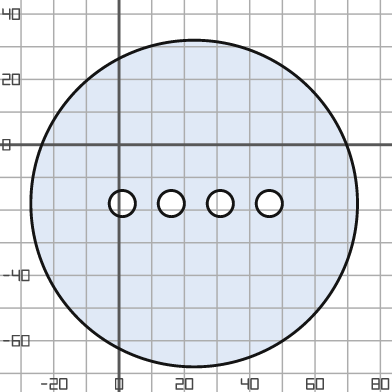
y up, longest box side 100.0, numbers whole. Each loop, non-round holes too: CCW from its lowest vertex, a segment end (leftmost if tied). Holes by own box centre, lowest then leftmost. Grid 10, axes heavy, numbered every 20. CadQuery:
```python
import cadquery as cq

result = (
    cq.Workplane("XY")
    .moveTo(23.0, -18.0)
    .circle(50.0)
    .moveTo(1.0, -18.0)
    .circle(4.0)
    .moveTo(16.0, -18.0)
    .circle(4.0)
    .moveTo(31.0, -18.0)
    .circle(4.0)
    .moveTo(46.0, -18.0)
    .circle(4.0)
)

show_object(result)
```